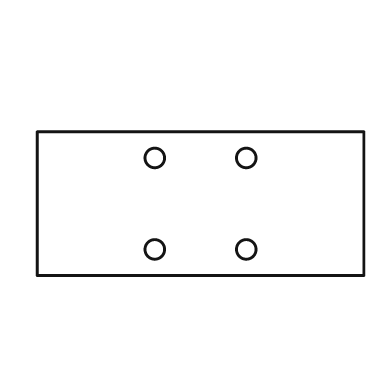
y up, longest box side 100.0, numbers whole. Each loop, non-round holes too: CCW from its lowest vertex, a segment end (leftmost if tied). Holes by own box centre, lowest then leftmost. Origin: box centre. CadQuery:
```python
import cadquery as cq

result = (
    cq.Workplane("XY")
    .moveTo(-50.0, -22.0)
    .lineTo(50.0, -22.0)
    .lineTo(50.0, 22.0)
    .lineTo(-50.0, 22.0)
    .close()
    .moveTo(-14.0, -14.0)
    .circle(3.0)
    .moveTo(14.0, -14.0)
    .circle(3.0)
    .moveTo(-14.0, 14.0)
    .circle(3.0)
    .moveTo(14.0, 14.0)
    .circle(3.0)
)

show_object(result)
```